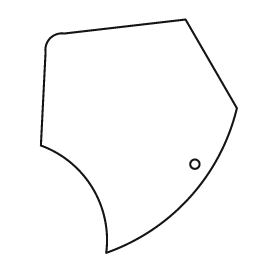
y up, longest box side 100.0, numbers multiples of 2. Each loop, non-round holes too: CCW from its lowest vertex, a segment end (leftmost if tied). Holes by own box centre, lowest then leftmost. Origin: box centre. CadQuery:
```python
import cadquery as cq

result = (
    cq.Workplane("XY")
    .moveTo(-14.0, -50.0)
    .threePointArc((22.0, -26.0), (42.0, 12.0))
    .lineTo(20.0, 50.0)
    .lineTo(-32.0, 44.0)
    .threePointArc((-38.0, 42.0), (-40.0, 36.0))
    .lineTo(-42.0, -4.0)
    .threePointArc((-20.0, -22.0), (-14.0, -50.0))
    .close()
    .moveTo(24.0, -12.0)
    .circle(2.0)
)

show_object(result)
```